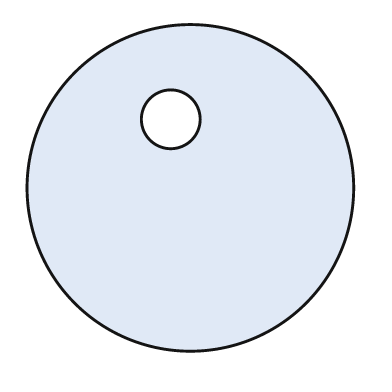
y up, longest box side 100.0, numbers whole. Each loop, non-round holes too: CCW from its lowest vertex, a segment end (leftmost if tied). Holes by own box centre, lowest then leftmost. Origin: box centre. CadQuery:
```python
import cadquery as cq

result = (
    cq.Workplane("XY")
    .moveTo(0.0, 0.0)
    .circle(50.0)
    .moveTo(-6.0, 21.0)
    .circle(9.0)
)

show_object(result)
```